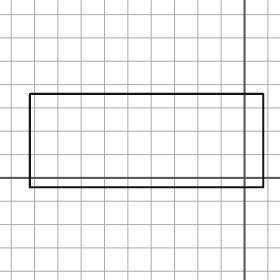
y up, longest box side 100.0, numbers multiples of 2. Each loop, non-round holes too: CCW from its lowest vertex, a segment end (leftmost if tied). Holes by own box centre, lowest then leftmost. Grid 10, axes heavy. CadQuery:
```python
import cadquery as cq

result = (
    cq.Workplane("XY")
    .moveTo(-92.0, -4.0)
    .lineTo(8.0, -4.0)
    .lineTo(8.0, 36.0)
    .lineTo(-92.0, 36.0)
    .close()
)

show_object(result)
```